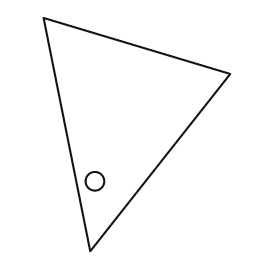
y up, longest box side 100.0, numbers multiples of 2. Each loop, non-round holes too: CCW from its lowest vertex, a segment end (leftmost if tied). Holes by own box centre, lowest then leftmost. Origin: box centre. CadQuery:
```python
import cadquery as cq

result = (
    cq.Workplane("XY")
    .moveTo(-20.0, -50.0)
    .lineTo(40.0, 26.0)
    .lineTo(-40.0, 50.0)
    .close()
    .moveTo(-18.0, -20.0)
    .circle(4.0)
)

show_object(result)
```